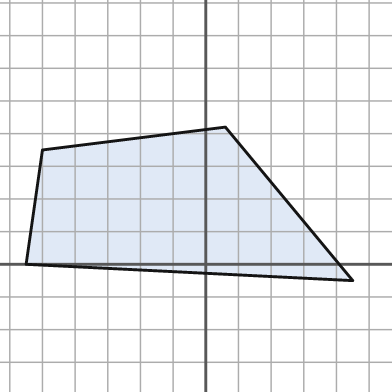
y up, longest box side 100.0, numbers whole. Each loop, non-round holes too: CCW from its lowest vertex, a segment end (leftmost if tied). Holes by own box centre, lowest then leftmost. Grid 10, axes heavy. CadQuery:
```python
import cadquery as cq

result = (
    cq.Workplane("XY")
    .moveTo(45.0, -5.0)
    .lineTo(6.0, 42.0)
    .lineTo(-50.0, 35.0)
    .lineTo(-55.0, 0.0)
    .close()
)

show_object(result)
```